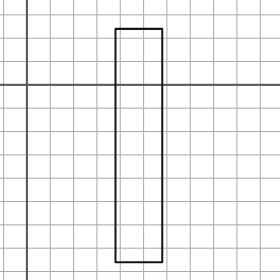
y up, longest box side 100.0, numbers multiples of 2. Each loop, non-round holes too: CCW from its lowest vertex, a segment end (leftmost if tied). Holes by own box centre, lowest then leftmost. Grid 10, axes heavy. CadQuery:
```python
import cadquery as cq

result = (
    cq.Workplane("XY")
    .moveTo(38.0, -76.0)
    .lineTo(58.0, -76.0)
    .lineTo(58.0, 24.0)
    .lineTo(38.0, 24.0)
    .close()
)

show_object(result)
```